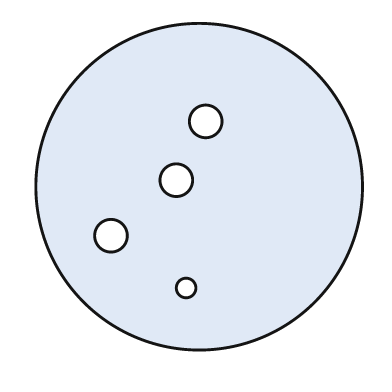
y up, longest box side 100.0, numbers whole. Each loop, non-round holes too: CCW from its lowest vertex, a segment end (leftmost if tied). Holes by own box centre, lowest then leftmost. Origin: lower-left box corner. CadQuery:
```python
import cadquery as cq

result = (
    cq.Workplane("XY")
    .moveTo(50.0, 50.0)
    .circle(50.0)
    .moveTo(46.0, 19.0)
    .circle(3.0)
    .moveTo(23.0, 35.0)
    .circle(5.0)
    .moveTo(43.0, 52.0)
    .circle(5.0)
    .moveTo(52.0, 70.0)
    .circle(5.0)
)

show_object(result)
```